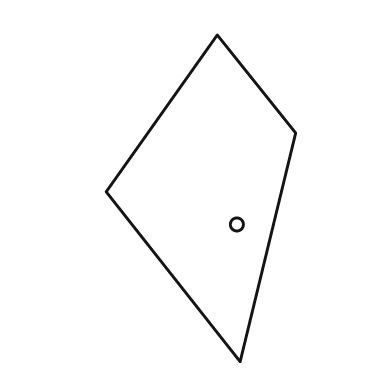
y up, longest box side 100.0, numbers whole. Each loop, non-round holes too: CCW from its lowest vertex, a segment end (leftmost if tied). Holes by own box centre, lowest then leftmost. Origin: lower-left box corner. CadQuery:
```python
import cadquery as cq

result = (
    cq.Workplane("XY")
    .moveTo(41.0, 0.0)
    .lineTo(58.0, 70.0)
    .lineTo(34.0, 100.0)
    .lineTo(0.0, 52.0)
    .close()
    .moveTo(40.0, 42.0)
    .circle(2.0)
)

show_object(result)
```